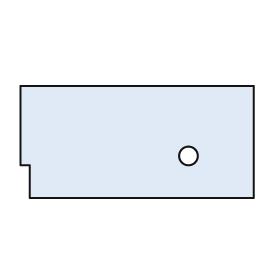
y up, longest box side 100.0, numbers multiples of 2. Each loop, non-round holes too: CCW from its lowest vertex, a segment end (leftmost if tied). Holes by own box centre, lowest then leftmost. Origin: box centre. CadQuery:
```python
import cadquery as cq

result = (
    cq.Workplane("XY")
    .moveTo(-46.0, -24.0)
    .lineTo(50.0, -24.0)
    .lineTo(50.0, 24.0)
    .lineTo(-50.0, 24.0)
    .lineTo(-50.0, -10.0)
    .lineTo(-46.0, -10.0)
    .close()
    .moveTo(22.0, -6.0)
    .circle(4.0)
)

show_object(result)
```